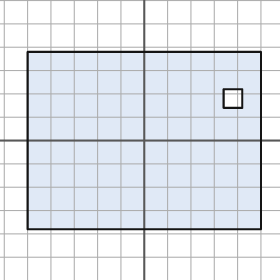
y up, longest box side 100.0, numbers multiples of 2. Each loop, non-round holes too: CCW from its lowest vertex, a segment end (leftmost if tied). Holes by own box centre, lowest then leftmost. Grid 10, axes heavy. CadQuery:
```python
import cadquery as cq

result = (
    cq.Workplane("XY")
    .moveTo(-50.0, -38.0)
    .lineTo(50.0, -38.0)
    .lineTo(50.0, 38.0)
    .lineTo(-50.0, 38.0)
    .close()
    .moveTo(34.0, 14.0)
    .lineTo(42.0, 14.0)
    .lineTo(42.0, 22.0)
    .lineTo(34.0, 22.0)
    .close()
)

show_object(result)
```